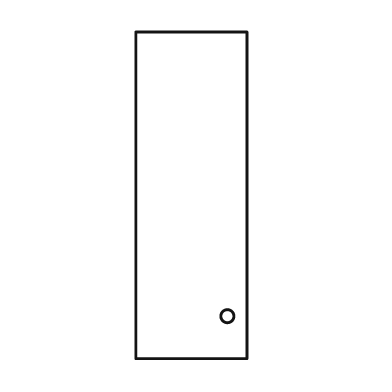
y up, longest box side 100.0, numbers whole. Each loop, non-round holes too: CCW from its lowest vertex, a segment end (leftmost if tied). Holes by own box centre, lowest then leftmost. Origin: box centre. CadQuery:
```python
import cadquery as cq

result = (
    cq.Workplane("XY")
    .moveTo(-17.0, -50.0)
    .lineTo(17.0, -50.0)
    .lineTo(17.0, 50.0)
    .lineTo(-17.0, 50.0)
    .close()
    .moveTo(11.0, -37.0)
    .circle(2.0)
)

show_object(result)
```